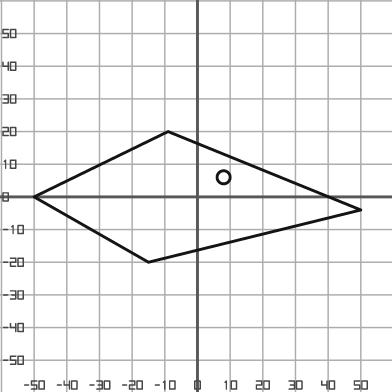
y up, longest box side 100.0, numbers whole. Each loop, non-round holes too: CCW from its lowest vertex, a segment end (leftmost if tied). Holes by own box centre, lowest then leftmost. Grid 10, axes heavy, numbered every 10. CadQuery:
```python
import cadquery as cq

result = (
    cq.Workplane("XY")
    .moveTo(-15.0, -20.0)
    .lineTo(50.0, -4.0)
    .lineTo(-9.0, 20.0)
    .lineTo(-50.0, 0.0)
    .close()
    .moveTo(8.0, 6.0)
    .circle(2.0)
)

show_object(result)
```